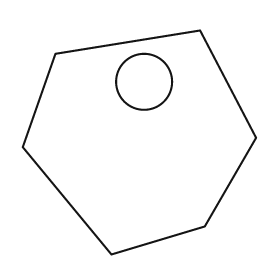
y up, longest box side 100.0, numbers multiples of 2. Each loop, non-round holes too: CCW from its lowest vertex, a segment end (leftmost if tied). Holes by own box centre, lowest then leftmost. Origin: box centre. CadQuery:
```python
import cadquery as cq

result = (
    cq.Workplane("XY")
    .moveTo(-12.0, -48.0)
    .lineTo(28.0, -36.0)
    .lineTo(50.0, 2.0)
    .lineTo(26.0, 48.0)
    .lineTo(-36.0, 38.0)
    .lineTo(-50.0, -2.0)
    .close()
    .moveTo(2.0, 26.0)
    .circle(12.0)
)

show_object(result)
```